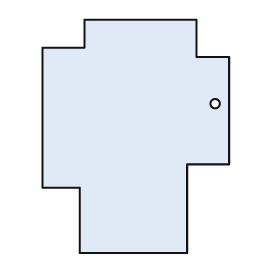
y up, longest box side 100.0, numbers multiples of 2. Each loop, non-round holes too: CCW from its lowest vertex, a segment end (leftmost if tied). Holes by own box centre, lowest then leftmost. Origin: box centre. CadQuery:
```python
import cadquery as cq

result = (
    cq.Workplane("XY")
    .moveTo(-24.0, -50.0)
    .lineTo(22.0, -50.0)
    .lineTo(22.0, -12.0)
    .lineTo(40.0, -12.0)
    .lineTo(40.0, 34.0)
    .lineTo(26.0, 34.0)
    .lineTo(26.0, 50.0)
    .lineTo(-22.0, 50.0)
    .lineTo(-22.0, 38.0)
    .lineTo(-40.0, 38.0)
    .lineTo(-40.0, -22.0)
    .lineTo(-24.0, -22.0)
    .close()
    .moveTo(34.0, 14.0)
    .circle(2.0)
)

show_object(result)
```